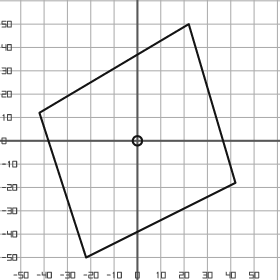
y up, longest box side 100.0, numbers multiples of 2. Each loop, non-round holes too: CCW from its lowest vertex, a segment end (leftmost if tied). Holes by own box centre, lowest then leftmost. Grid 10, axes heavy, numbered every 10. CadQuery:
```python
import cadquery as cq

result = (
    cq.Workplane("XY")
    .moveTo(-22.0, -50.0)
    .lineTo(42.0, -18.0)
    .lineTo(22.0, 50.0)
    .lineTo(-42.0, 12.0)
    .close()
    .moveTo(0.0, 0.0)
    .circle(2.0)
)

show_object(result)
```